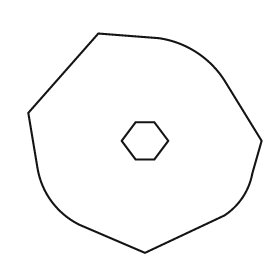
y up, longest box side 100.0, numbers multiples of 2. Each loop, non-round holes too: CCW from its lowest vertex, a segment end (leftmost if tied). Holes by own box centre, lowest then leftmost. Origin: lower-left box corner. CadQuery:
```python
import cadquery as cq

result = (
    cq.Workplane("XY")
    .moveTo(50.0, 0.0)
    .lineTo(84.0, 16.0)
    .threePointArc((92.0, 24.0), (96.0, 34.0))
    .lineTo(100.0, 48.0)
    .lineTo(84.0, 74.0)
    .threePointArc((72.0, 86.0), (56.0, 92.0))
    .lineTo(30.0, 94.0)
    .lineTo(0.0, 60.0)
    .lineTo(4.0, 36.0)
    .threePointArc((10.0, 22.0), (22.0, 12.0))
    .close()
    .moveTo(46.0, 40.0)
    .lineTo(54.0, 40.0)
    .lineTo(60.0, 48.0)
    .lineTo(54.0, 56.0)
    .lineTo(46.0, 56.0)
    .lineTo(40.0, 48.0)
    .close()
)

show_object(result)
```